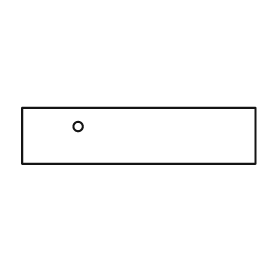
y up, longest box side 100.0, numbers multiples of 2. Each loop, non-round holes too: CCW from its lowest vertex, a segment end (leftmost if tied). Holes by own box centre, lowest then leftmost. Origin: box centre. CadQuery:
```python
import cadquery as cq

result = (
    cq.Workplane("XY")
    .moveTo(-50.0, -12.0)
    .lineTo(50.0, -12.0)
    .lineTo(50.0, 12.0)
    .lineTo(-50.0, 12.0)
    .close()
    .moveTo(-26.0, 4.0)
    .circle(2.0)
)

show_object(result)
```